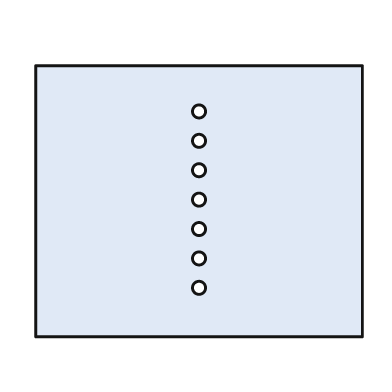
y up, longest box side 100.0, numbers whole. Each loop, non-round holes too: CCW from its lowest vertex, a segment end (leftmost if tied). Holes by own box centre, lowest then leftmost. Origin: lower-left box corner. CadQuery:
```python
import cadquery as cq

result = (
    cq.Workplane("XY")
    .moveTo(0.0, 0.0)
    .lineTo(100.0, 0.0)
    .lineTo(100.0, 83.0)
    .lineTo(0.0, 83.0)
    .close()
    .moveTo(50.0, 15.0)
    .circle(2.0)
    .moveTo(50.0, 24.0)
    .circle(2.0)
    .moveTo(50.0, 33.0)
    .circle(2.0)
    .moveTo(50.0, 42.0)
    .circle(2.0)
    .moveTo(50.0, 51.0)
    .circle(2.0)
    .moveTo(50.0, 60.0)
    .circle(2.0)
    .moveTo(50.0, 69.0)
    .circle(2.0)
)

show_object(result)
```